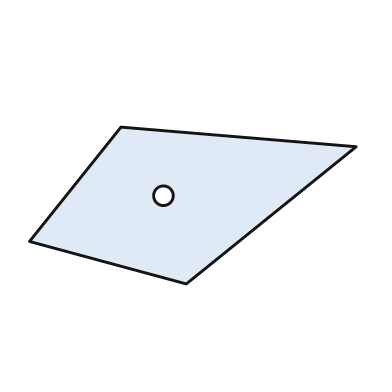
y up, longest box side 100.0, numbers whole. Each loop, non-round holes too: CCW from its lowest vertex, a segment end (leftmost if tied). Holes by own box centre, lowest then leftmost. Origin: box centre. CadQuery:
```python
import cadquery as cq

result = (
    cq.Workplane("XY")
    .moveTo(-2.0, -24.0)
    .lineTo(50.0, 18.0)
    .lineTo(-22.0, 24.0)
    .lineTo(-50.0, -11.0)
    .close()
    .moveTo(-9.0, 3.0)
    .circle(3.0)
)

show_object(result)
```